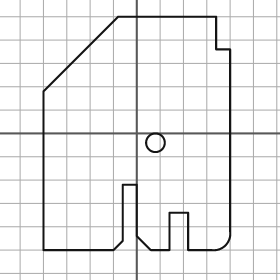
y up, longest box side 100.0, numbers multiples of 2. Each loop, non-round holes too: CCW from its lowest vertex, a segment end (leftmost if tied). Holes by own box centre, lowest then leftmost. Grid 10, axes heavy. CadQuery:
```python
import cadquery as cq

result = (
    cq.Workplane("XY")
    .moveTo(-40.0, -50.0)
    .lineTo(-10.0, -50.0)
    .lineTo(-6.0, -46.0)
    .lineTo(-6.0, -22.0)
    .lineTo(0.0, -22.0)
    .lineTo(0.0, -44.0)
    .lineTo(6.0, -50.0)
    .lineTo(14.0, -50.0)
    .lineTo(14.0, -34.0)
    .lineTo(22.0, -34.0)
    .lineTo(22.0, -50.0)
    .lineTo(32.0, -50.0)
    .threePointArc((38.0, -48.0), (40.0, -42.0))
    .lineTo(40.0, 36.0)
    .lineTo(34.0, 36.0)
    .lineTo(34.0, 50.0)
    .lineTo(-8.0, 50.0)
    .lineTo(-40.0, 18.0)
    .close()
    .moveTo(8.0, -4.0)
    .circle(4.0)
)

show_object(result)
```